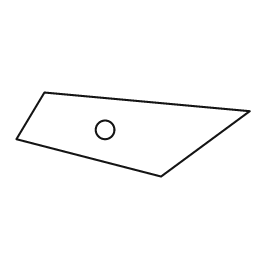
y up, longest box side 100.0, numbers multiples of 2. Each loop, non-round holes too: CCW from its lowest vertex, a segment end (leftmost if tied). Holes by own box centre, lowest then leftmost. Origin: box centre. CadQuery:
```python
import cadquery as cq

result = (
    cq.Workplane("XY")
    .moveTo(12.0, -18.0)
    .lineTo(50.0, 10.0)
    .lineTo(-38.0, 18.0)
    .lineTo(-50.0, -2.0)
    .close()
    .moveTo(-12.0, 2.0)
    .circle(4.0)
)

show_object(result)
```